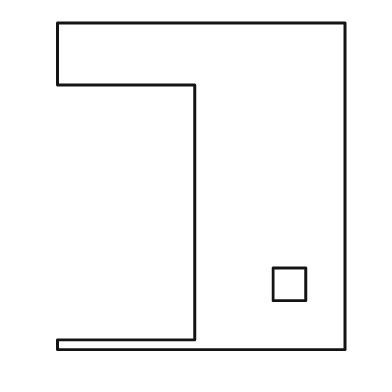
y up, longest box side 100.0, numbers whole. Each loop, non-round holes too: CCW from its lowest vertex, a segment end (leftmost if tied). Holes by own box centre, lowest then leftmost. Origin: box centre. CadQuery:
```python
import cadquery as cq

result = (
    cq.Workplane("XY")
    .moveTo(-44.0, -50.0)
    .lineTo(44.0, -50.0)
    .lineTo(44.0, 50.0)
    .lineTo(-44.0, 50.0)
    .lineTo(-44.0, 31.0)
    .lineTo(-2.0, 31.0)
    .lineTo(-2.0, -47.0)
    .lineTo(-44.0, -47.0)
    .close()
    .moveTo(22.0, -35.0)
    .lineTo(32.0, -35.0)
    .lineTo(32.0, -25.0)
    .lineTo(22.0, -25.0)
    .close()
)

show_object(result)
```